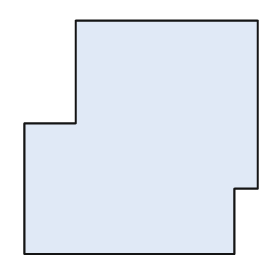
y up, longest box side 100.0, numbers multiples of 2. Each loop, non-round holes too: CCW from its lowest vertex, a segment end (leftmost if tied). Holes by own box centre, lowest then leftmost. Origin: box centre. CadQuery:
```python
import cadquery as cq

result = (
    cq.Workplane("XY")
    .moveTo(-50.0, -50.0)
    .lineTo(40.0, -50.0)
    .lineTo(40.0, -22.0)
    .lineTo(50.0, -22.0)
    .lineTo(50.0, 50.0)
    .lineTo(-28.0, 50.0)
    .lineTo(-28.0, 6.0)
    .lineTo(-50.0, 6.0)
    .close()
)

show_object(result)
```